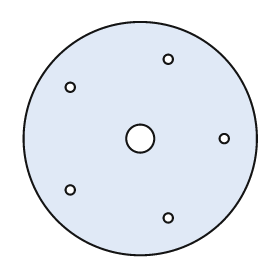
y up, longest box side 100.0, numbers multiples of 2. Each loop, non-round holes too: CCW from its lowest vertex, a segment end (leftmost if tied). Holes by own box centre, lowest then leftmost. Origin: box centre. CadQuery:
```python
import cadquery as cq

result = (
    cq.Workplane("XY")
    .moveTo(0.0, 0.0)
    .circle(50.0)
    .moveTo(12.0, -34.0)
    .circle(2.0)
    .moveTo(-30.0, -22.0)
    .circle(2.0)
    .moveTo(0.0, 0.0)
    .circle(6.0)
    .moveTo(36.0, 0.0)
    .circle(2.0)
    .moveTo(-30.0, 22.0)
    .circle(2.0)
    .moveTo(12.0, 34.0)
    .circle(2.0)
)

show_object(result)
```